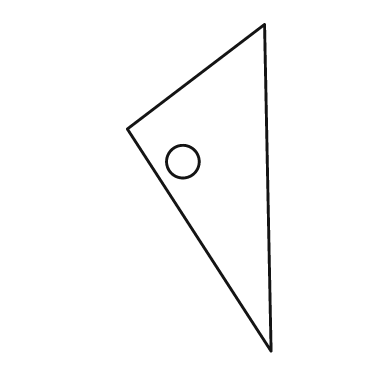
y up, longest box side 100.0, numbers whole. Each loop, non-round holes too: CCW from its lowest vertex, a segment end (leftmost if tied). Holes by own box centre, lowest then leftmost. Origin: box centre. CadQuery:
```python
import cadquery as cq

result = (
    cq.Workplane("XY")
    .moveTo(22.0, -50.0)
    .lineTo(20.0, 50.0)
    .lineTo(-22.0, 18.0)
    .close()
    .moveTo(-5.0, 8.0)
    .circle(5.0)
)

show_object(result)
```